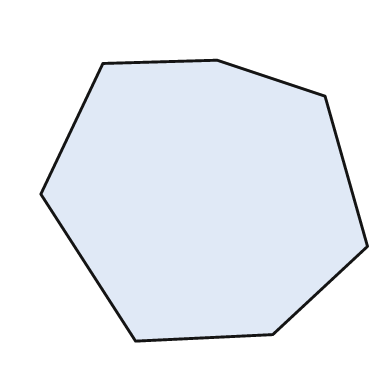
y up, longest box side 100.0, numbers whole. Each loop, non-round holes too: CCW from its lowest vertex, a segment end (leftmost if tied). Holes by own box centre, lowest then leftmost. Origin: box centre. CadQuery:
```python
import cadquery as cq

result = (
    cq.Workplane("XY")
    .moveTo(-21.0, -43.0)
    .lineTo(21.0, -41.0)
    .lineTo(50.0, -14.0)
    .lineTo(37.0, 32.0)
    .lineTo(4.0, 43.0)
    .lineTo(-31.0, 42.0)
    .lineTo(-50.0, 2.0)
    .close()
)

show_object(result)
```